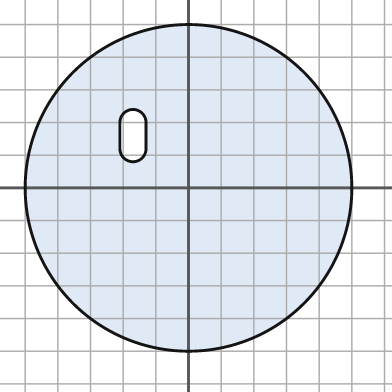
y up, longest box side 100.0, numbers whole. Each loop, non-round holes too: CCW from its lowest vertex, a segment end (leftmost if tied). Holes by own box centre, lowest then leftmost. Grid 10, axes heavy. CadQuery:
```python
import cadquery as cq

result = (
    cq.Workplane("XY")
    .moveTo(0.0, 0.0)
    .circle(50.0)
    .moveTo(-21.0, 12.0)
    .threePointArc((-17.0, 8.0), (-13.0, 12.0))
    .lineTo(-13.0, 20.0)
    .threePointArc((-17.0, 24.0), (-21.0, 20.0))
    .close()
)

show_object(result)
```